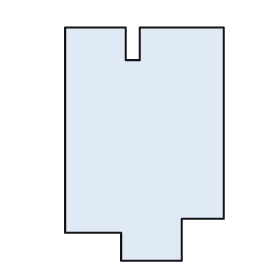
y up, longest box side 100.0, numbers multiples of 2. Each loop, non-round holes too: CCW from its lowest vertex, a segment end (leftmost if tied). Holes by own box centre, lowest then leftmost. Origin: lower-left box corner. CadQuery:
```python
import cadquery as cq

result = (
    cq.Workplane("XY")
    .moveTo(24.0, 0.0)
    .lineTo(50.0, 0.0)
    .lineTo(50.0, 18.0)
    .lineTo(68.0, 18.0)
    .lineTo(68.0, 100.0)
    .lineTo(32.0, 100.0)
    .lineTo(32.0, 86.0)
    .lineTo(26.0, 86.0)
    .lineTo(26.0, 100.0)
    .lineTo(0.0, 100.0)
    .lineTo(0.0, 12.0)
    .lineTo(24.0, 12.0)
    .close()
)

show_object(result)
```